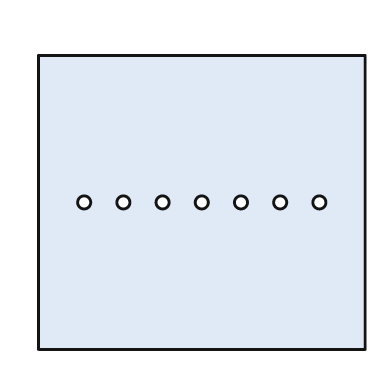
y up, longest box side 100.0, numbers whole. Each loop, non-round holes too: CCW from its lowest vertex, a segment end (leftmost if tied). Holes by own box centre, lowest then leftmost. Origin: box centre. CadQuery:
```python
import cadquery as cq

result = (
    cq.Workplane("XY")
    .moveTo(-50.0, -45.0)
    .lineTo(50.0, -45.0)
    .lineTo(50.0, 45.0)
    .lineTo(-50.0, 45.0)
    .close()
    .moveTo(-36.0, 0.0)
    .circle(2.0)
    .moveTo(-24.0, 0.0)
    .circle(2.0)
    .moveTo(-12.0, 0.0)
    .circle(2.0)
    .moveTo(0.0, 0.0)
    .circle(2.0)
    .moveTo(12.0, 0.0)
    .circle(2.0)
    .moveTo(24.0, 0.0)
    .circle(2.0)
    .moveTo(36.0, 0.0)
    .circle(2.0)
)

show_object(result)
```